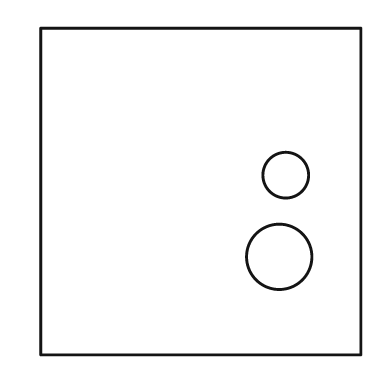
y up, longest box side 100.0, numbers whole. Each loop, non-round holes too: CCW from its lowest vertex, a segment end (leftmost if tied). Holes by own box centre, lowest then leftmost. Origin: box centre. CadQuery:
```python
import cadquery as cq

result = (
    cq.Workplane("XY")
    .moveTo(-49.0, -50.0)
    .lineTo(49.0, -50.0)
    .lineTo(49.0, 50.0)
    .lineTo(-49.0, 50.0)
    .close()
    .moveTo(24.0, -20.0)
    .circle(10.0)
    .moveTo(26.0, 5.0)
    .circle(7.0)
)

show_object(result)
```